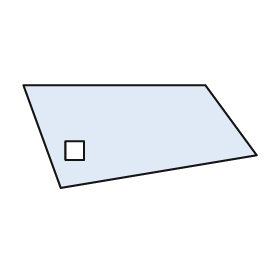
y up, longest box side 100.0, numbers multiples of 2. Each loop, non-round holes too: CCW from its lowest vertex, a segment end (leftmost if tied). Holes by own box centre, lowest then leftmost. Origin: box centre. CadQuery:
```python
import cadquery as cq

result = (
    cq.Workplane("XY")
    .moveTo(-34.0, -22.0)
    .lineTo(50.0, -8.0)
    .lineTo(28.0, 22.0)
    .lineTo(-50.0, 22.0)
    .close()
    .moveTo(-32.0, -10.0)
    .lineTo(-24.0, -10.0)
    .lineTo(-24.0, -2.0)
    .lineTo(-32.0, -2.0)
    .close()
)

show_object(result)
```